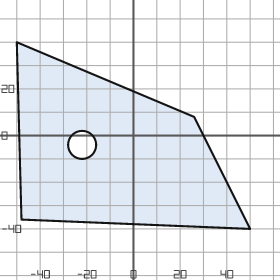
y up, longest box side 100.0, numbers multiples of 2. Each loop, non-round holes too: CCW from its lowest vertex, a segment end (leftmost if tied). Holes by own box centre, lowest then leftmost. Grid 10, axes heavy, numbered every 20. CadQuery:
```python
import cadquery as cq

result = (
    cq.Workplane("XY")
    .moveTo(50.0, -40.0)
    .lineTo(26.0, 8.0)
    .lineTo(-50.0, 40.0)
    .lineTo(-48.0, -36.0)
    .close()
    .moveTo(-22.0, -4.0)
    .circle(6.0)
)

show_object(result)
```